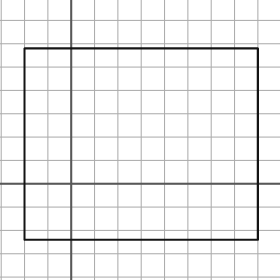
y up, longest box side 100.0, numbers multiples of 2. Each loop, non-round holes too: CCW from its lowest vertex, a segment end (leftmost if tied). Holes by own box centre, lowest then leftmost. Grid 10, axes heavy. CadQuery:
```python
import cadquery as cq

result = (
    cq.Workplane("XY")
    .moveTo(-20.0, -24.0)
    .lineTo(80.0, -24.0)
    .lineTo(80.0, 58.0)
    .lineTo(-20.0, 58.0)
    .close()
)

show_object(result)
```